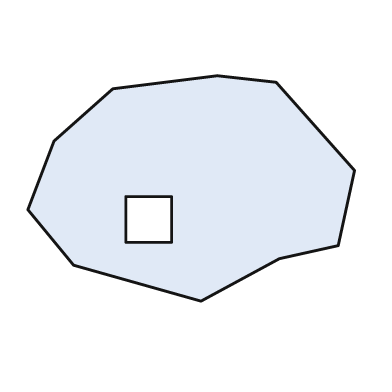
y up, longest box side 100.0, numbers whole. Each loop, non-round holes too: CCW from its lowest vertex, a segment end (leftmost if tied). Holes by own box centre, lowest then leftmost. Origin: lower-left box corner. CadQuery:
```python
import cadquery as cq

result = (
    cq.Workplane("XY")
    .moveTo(53.0, 0.0)
    .lineTo(77.0, 13.0)
    .lineTo(95.0, 17.0)
    .lineTo(100.0, 40.0)
    .lineTo(76.0, 67.0)
    .lineTo(58.0, 69.0)
    .lineTo(26.0, 65.0)
    .lineTo(8.0, 49.0)
    .lineTo(0.0, 28.0)
    .lineTo(14.0, 11.0)
    .close()
    .moveTo(30.0, 18.0)
    .lineTo(44.0, 18.0)
    .lineTo(44.0, 32.0)
    .lineTo(30.0, 32.0)
    .close()
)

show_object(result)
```